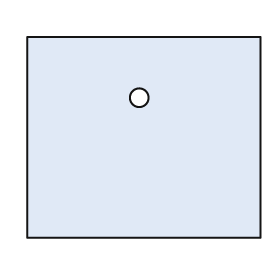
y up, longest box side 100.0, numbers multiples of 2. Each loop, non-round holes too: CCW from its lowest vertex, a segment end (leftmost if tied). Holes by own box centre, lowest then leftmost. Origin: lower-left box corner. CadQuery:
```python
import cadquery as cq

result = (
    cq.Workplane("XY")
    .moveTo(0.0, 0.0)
    .lineTo(100.0, 0.0)
    .lineTo(100.0, 86.0)
    .lineTo(0.0, 86.0)
    .close()
    .moveTo(48.0, 60.0)
    .circle(4.0)
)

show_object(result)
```